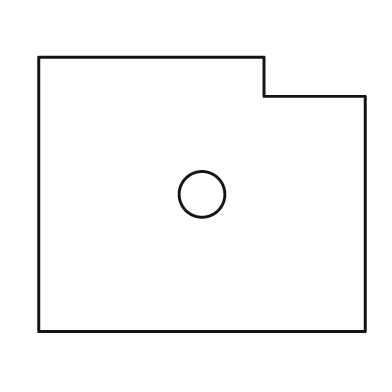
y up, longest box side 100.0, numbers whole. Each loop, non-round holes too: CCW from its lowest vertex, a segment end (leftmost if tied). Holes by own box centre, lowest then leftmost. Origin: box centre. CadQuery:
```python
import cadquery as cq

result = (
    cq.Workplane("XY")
    .moveTo(-50.0, -42.0)
    .lineTo(50.0, -42.0)
    .lineTo(50.0, 30.0)
    .lineTo(19.0, 30.0)
    .lineTo(19.0, 42.0)
    .lineTo(-50.0, 42.0)
    .close()
    .moveTo(0.0, 0.0)
    .circle(7.0)
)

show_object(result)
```